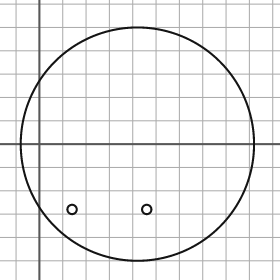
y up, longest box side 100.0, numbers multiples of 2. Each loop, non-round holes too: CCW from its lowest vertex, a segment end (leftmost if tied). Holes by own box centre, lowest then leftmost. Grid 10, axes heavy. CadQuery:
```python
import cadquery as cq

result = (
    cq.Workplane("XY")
    .moveTo(42.0, 0.0)
    .circle(50.0)
    .moveTo(14.0, -28.0)
    .circle(2.0)
    .moveTo(46.0, -28.0)
    .circle(2.0)
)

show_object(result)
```